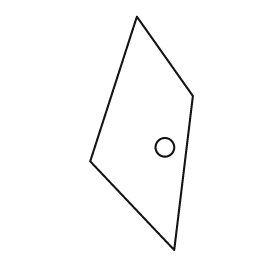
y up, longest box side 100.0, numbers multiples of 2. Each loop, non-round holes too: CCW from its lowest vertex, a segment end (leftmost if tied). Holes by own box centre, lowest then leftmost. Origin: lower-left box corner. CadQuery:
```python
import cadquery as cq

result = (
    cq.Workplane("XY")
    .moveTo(36.0, 0.0)
    .lineTo(44.0, 66.0)
    .lineTo(20.0, 100.0)
    .lineTo(0.0, 38.0)
    .close()
    .moveTo(32.0, 44.0)
    .circle(4.0)
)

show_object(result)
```